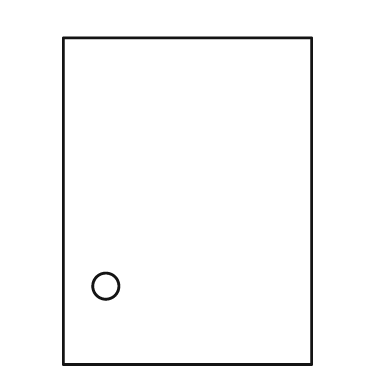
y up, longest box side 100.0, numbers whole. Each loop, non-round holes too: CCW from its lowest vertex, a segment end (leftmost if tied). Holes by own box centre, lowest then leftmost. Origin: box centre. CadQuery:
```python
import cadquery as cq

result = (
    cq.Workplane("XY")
    .moveTo(-38.0, -50.0)
    .lineTo(38.0, -50.0)
    .lineTo(38.0, 50.0)
    .lineTo(-38.0, 50.0)
    .close()
    .moveTo(-25.0, -26.0)
    .circle(4.0)
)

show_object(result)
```